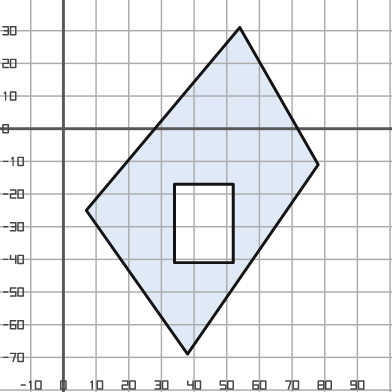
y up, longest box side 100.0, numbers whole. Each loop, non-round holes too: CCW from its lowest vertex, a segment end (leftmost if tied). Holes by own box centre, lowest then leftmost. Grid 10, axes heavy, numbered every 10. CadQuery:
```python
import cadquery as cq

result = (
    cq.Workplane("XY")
    .moveTo(38.0, -69.0)
    .lineTo(78.0, -11.0)
    .lineTo(54.0, 31.0)
    .lineTo(7.0, -25.0)
    .close()
    .moveTo(34.0, -41.0)
    .lineTo(52.0, -41.0)
    .lineTo(52.0, -17.0)
    .lineTo(34.0, -17.0)
    .close()
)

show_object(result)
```